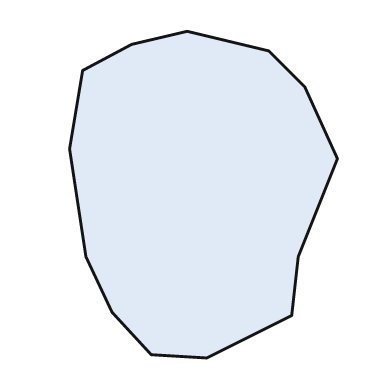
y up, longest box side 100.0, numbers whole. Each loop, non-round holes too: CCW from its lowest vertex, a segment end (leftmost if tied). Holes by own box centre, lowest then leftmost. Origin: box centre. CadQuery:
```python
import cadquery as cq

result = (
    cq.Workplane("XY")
    .moveTo(1.0, -50.0)
    .lineTo(27.0, -37.0)
    .lineTo(29.0, -19.0)
    .lineTo(41.0, 11.0)
    .lineTo(31.0, 33.0)
    .lineTo(20.0, 44.0)
    .lineTo(-5.0, 50.0)
    .lineTo(-22.0, 46.0)
    .lineTo(-37.0, 38.0)
    .lineTo(-41.0, 14.0)
    .lineTo(-36.0, -19.0)
    .lineTo(-28.0, -36.0)
    .lineTo(-16.0, -49.0)
    .close()
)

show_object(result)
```